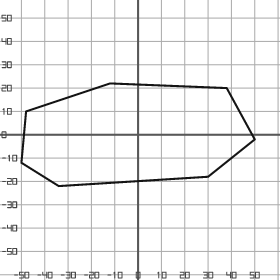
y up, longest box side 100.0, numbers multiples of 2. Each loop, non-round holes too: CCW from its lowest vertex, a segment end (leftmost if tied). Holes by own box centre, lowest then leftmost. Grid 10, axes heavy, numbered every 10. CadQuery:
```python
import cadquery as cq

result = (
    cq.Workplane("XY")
    .moveTo(-34.0, -22.0)
    .lineTo(30.0, -18.0)
    .lineTo(50.0, -2.0)
    .lineTo(38.0, 20.0)
    .lineTo(-12.0, 22.0)
    .lineTo(-48.0, 10.0)
    .lineTo(-50.0, -12.0)
    .close()
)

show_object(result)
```